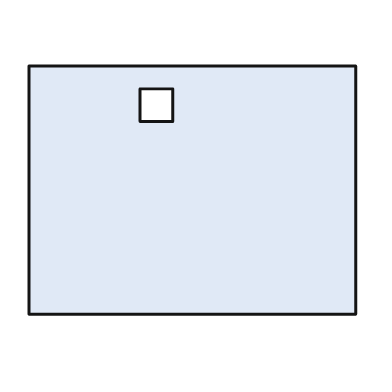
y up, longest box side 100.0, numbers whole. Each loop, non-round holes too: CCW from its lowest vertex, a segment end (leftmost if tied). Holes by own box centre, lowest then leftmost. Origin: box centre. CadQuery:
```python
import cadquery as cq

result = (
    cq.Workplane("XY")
    .moveTo(-50.0, -38.0)
    .lineTo(50.0, -38.0)
    .lineTo(50.0, 38.0)
    .lineTo(-50.0, 38.0)
    .close()
    .moveTo(-16.0, 21.0)
    .lineTo(-6.0, 21.0)
    .lineTo(-6.0, 31.0)
    .lineTo(-16.0, 31.0)
    .close()
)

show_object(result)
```